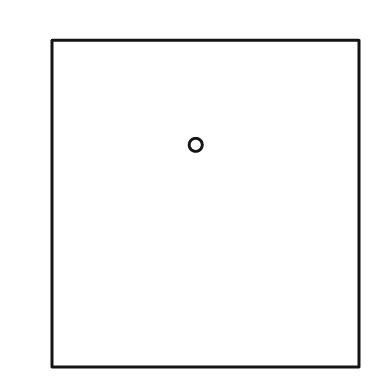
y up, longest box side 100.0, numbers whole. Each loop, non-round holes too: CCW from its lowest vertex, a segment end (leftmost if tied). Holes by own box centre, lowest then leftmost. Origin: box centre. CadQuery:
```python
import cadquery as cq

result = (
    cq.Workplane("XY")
    .moveTo(-47.0, -50.0)
    .lineTo(47.0, -50.0)
    .lineTo(47.0, 50.0)
    .lineTo(-47.0, 50.0)
    .close()
    .moveTo(-3.0, 18.0)
    .circle(2.0)
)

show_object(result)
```